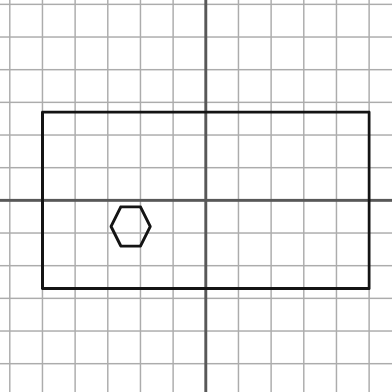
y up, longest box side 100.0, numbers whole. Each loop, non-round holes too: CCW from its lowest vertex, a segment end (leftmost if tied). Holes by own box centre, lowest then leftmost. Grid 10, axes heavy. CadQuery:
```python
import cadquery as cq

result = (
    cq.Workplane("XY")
    .moveTo(-50.0, -27.0)
    .lineTo(50.0, -27.0)
    .lineTo(50.0, 27.0)
    .lineTo(-50.0, 27.0)
    .close()
    .moveTo(-26.0, -14.0)
    .lineTo(-20.0, -14.0)
    .lineTo(-17.0, -8.0)
    .lineTo(-20.0, -2.0)
    .lineTo(-26.0, -2.0)
    .lineTo(-29.0, -8.0)
    .close()
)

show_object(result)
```